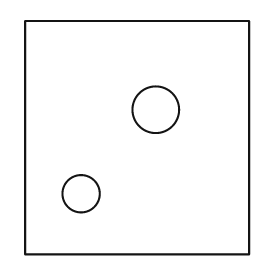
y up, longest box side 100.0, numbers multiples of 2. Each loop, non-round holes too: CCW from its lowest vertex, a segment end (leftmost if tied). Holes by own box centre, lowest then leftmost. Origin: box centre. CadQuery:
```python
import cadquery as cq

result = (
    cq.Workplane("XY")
    .moveTo(-48.0, -50.0)
    .lineTo(48.0, -50.0)
    .lineTo(48.0, 50.0)
    .lineTo(-48.0, 50.0)
    .close()
    .moveTo(-24.0, -24.0)
    .circle(8.0)
    .moveTo(8.0, 12.0)
    .circle(10.0)
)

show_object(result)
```